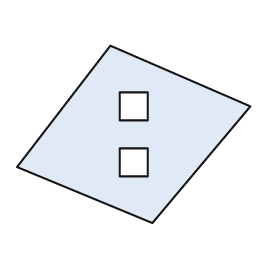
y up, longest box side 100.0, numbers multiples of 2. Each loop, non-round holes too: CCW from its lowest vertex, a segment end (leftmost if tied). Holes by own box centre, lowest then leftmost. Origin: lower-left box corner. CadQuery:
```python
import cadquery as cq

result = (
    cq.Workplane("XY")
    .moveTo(58.0, 0.0)
    .lineTo(100.0, 50.0)
    .lineTo(40.0, 76.0)
    .lineTo(0.0, 24.0)
    .close()
    .moveTo(44.0, 20.0)
    .lineTo(56.0, 20.0)
    .lineTo(56.0, 32.0)
    .lineTo(44.0, 32.0)
    .close()
    .moveTo(44.0, 44.0)
    .lineTo(56.0, 44.0)
    .lineTo(56.0, 56.0)
    .lineTo(44.0, 56.0)
    .close()
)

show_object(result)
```